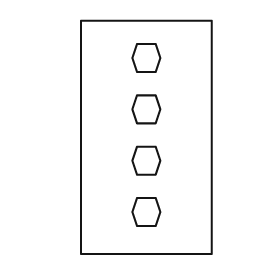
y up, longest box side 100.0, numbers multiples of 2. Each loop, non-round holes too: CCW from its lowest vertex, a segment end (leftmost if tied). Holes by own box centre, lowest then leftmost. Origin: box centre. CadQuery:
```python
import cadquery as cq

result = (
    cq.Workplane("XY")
    .moveTo(-28.0, -50.0)
    .lineTo(28.0, -50.0)
    .lineTo(28.0, 50.0)
    .lineTo(-28.0, 50.0)
    .close()
    .moveTo(-4.0, -38.0)
    .lineTo(4.0, -38.0)
    .lineTo(6.0, -32.0)
    .lineTo(4.0, -26.0)
    .lineTo(-4.0, -26.0)
    .lineTo(-6.0, -32.0)
    .close()
    .moveTo(-4.0, -16.0)
    .lineTo(4.0, -16.0)
    .lineTo(6.0, -10.0)
    .lineTo(4.0, -4.0)
    .lineTo(-4.0, -4.0)
    .lineTo(-6.0, -10.0)
    .close()
    .moveTo(-4.0, 6.0)
    .lineTo(4.0, 6.0)
    .lineTo(6.0, 12.0)
    .lineTo(4.0, 18.0)
    .lineTo(-4.0, 18.0)
    .lineTo(-6.0, 12.0)
    .close()
    .moveTo(-4.0, 28.0)
    .lineTo(4.0, 28.0)
    .lineTo(6.0, 34.0)
    .lineTo(4.0, 40.0)
    .lineTo(-4.0, 40.0)
    .lineTo(-6.0, 34.0)
    .close()
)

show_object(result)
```